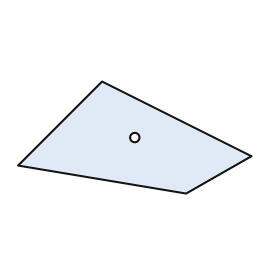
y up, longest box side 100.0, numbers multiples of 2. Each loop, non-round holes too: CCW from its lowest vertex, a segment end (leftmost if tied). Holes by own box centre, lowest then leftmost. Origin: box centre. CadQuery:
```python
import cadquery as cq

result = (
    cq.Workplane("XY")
    .moveTo(22.0, -24.0)
    .lineTo(50.0, -8.0)
    .lineTo(-14.0, 24.0)
    .lineTo(-50.0, -12.0)
    .close()
    .moveTo(0.0, 0.0)
    .circle(2.0)
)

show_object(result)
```